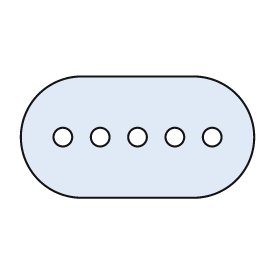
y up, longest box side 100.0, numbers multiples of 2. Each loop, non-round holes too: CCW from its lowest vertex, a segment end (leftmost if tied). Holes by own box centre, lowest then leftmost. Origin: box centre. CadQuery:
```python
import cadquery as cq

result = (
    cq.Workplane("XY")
    .moveTo(-24.0, -26.0)
    .lineTo(24.0, -26.0)
    .threePointArc((50.0, 0.0), (24.0, 26.0))
    .lineTo(-24.0, 26.0)
    .threePointArc((-50.0, 0.0), (-24.0, -26.0))
    .close()
    .moveTo(-32.0, 0.0)
    .circle(4.0)
    .moveTo(-16.0, 0.0)
    .circle(4.0)
    .moveTo(0.0, 0.0)
    .circle(4.0)
    .moveTo(16.0, 0.0)
    .circle(4.0)
    .moveTo(32.0, 0.0)
    .circle(4.0)
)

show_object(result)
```